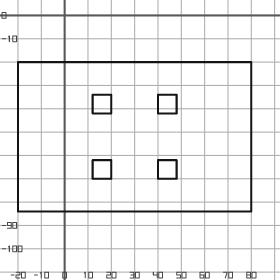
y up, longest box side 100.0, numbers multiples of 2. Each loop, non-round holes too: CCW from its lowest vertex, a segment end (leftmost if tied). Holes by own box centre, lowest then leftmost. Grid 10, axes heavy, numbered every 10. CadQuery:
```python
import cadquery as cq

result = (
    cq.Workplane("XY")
    .moveTo(-20.0, -84.0)
    .lineTo(80.0, -84.0)
    .lineTo(80.0, -20.0)
    .lineTo(-20.0, -20.0)
    .close()
    .moveTo(12.0, -70.0)
    .lineTo(20.0, -70.0)
    .lineTo(20.0, -62.0)
    .lineTo(12.0, -62.0)
    .close()
    .moveTo(40.0, -70.0)
    .lineTo(48.0, -70.0)
    .lineTo(48.0, -62.0)
    .lineTo(40.0, -62.0)
    .close()
    .moveTo(12.0, -42.0)
    .lineTo(20.0, -42.0)
    .lineTo(20.0, -34.0)
    .lineTo(12.0, -34.0)
    .close()
    .moveTo(40.0, -42.0)
    .lineTo(48.0, -42.0)
    .lineTo(48.0, -34.0)
    .lineTo(40.0, -34.0)
    .close()
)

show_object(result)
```